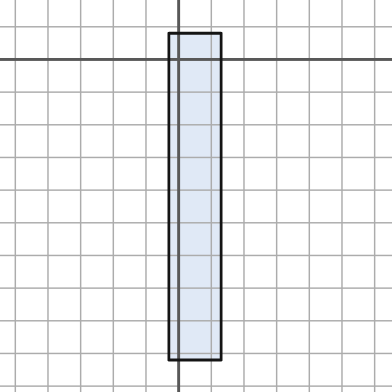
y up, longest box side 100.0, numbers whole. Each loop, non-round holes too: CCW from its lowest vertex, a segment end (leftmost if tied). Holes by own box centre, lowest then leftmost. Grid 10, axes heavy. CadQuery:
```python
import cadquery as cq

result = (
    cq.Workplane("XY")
    .moveTo(-3.0, -92.0)
    .lineTo(13.0, -92.0)
    .lineTo(13.0, 8.0)
    .lineTo(-3.0, 8.0)
    .close()
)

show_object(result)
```